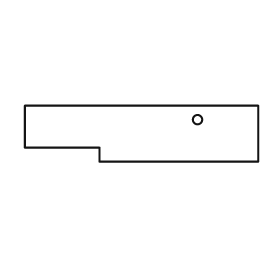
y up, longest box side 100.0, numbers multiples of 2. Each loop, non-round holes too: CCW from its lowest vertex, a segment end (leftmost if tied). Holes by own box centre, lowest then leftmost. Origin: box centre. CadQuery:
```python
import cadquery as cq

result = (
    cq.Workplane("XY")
    .moveTo(-18.0, -12.0)
    .lineTo(50.0, -12.0)
    .lineTo(50.0, 12.0)
    .lineTo(-50.0, 12.0)
    .lineTo(-50.0, -6.0)
    .lineTo(-18.0, -6.0)
    .close()
    .moveTo(24.0, 6.0)
    .circle(2.0)
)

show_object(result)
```